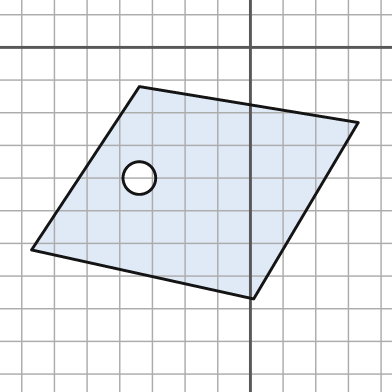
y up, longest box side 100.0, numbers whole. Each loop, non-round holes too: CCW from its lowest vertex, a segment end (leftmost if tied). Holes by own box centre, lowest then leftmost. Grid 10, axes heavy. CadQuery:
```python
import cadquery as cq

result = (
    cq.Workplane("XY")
    .moveTo(1.0, -77.0)
    .lineTo(33.0, -23.0)
    .lineTo(-34.0, -12.0)
    .lineTo(-67.0, -62.0)
    .close()
    .moveTo(-34.0, -40.0)
    .circle(5.0)
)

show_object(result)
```